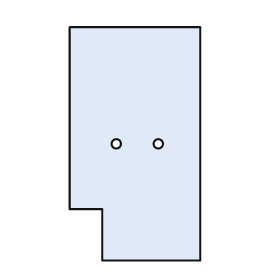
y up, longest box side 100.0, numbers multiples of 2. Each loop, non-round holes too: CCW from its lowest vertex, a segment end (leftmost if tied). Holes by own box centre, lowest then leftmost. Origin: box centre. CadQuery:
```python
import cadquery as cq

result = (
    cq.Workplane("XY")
    .moveTo(-14.0, -50.0)
    .lineTo(28.0, -50.0)
    .lineTo(28.0, 50.0)
    .lineTo(-28.0, 50.0)
    .lineTo(-28.0, -28.0)
    .lineTo(-14.0, -28.0)
    .close()
    .moveTo(-8.0, 0.0)
    .circle(2.0)
    .moveTo(10.0, 0.0)
    .circle(2.0)
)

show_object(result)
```